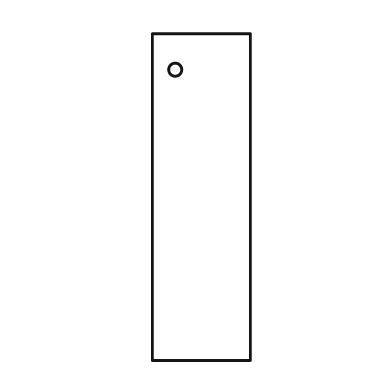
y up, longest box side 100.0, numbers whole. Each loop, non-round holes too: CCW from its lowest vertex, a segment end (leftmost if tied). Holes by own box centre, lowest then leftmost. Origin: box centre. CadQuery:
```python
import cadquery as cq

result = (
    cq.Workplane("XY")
    .moveTo(-15.0, -50.0)
    .lineTo(15.0, -50.0)
    .lineTo(15.0, 50.0)
    .lineTo(-15.0, 50.0)
    .close()
    .moveTo(-8.0, 39.0)
    .circle(2.0)
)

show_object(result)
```